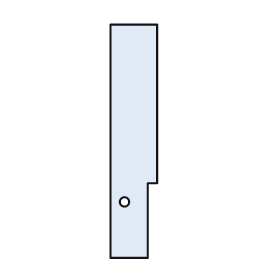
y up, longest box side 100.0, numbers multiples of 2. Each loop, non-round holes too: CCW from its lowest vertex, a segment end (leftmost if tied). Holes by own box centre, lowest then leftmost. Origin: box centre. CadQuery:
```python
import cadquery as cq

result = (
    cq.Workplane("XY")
    .moveTo(-10.0, -50.0)
    .lineTo(6.0, -50.0)
    .lineTo(6.0, -18.0)
    .lineTo(10.0, -18.0)
    .lineTo(10.0, 50.0)
    .lineTo(-10.0, 50.0)
    .close()
    .moveTo(-4.0, -26.0)
    .circle(2.0)
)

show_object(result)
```